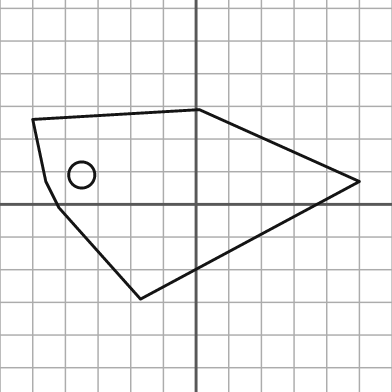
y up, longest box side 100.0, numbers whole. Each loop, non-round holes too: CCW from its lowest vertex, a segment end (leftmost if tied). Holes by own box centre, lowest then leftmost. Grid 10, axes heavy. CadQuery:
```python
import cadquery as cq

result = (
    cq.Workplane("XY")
    .moveTo(-17.0, -29.0)
    .lineTo(50.0, 7.0)
    .lineTo(1.0, 29.0)
    .lineTo(-50.0, 26.0)
    .lineTo(-46.0, 7.0)
    .lineTo(-42.0, -1.0)
    .close()
    .moveTo(-35.0, 9.0)
    .circle(4.0)
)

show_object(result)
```